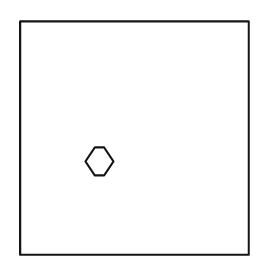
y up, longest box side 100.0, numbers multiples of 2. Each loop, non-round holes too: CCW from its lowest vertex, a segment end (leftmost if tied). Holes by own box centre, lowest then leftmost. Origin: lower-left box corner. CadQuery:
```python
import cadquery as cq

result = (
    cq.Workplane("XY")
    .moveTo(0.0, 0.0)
    .lineTo(98.0, 0.0)
    .lineTo(98.0, 100.0)
    .lineTo(0.0, 100.0)
    .close()
    .moveTo(32.0, 34.0)
    .lineTo(36.0, 34.0)
    .lineTo(40.0, 40.0)
    .lineTo(36.0, 46.0)
    .lineTo(32.0, 46.0)
    .lineTo(28.0, 40.0)
    .close()
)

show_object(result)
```